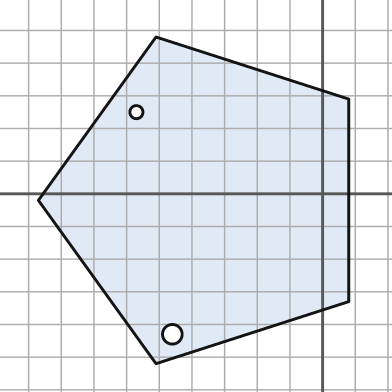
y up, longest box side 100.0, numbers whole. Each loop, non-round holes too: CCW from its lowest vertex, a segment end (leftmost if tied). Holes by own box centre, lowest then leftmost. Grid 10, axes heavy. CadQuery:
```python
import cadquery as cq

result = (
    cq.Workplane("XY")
    .moveTo(-51.0, -52.0)
    .lineTo(8.0, -33.0)
    .lineTo(8.0, 29.0)
    .lineTo(-51.0, 48.0)
    .lineTo(-87.0, -2.0)
    .close()
    .moveTo(-46.0, -43.0)
    .circle(3.0)
    .moveTo(-57.0, 25.0)
    .circle(2.0)
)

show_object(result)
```